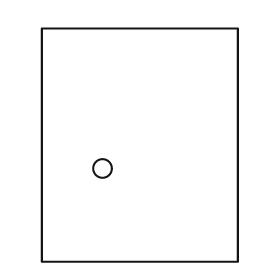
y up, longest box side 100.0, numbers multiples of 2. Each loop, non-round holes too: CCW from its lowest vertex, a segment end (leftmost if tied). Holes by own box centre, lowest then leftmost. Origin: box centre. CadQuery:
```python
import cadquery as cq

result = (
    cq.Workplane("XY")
    .moveTo(-42.0, -50.0)
    .lineTo(42.0, -50.0)
    .lineTo(42.0, 50.0)
    .lineTo(-42.0, 50.0)
    .close()
    .moveTo(-16.0, -10.0)
    .circle(4.0)
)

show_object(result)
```